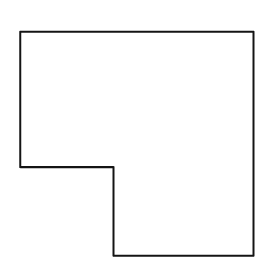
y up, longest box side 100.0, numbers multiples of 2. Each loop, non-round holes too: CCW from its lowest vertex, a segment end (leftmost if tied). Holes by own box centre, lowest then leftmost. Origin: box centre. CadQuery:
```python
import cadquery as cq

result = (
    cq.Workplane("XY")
    .moveTo(-10.0, -48.0)
    .lineTo(50.0, -48.0)
    .lineTo(50.0, 48.0)
    .lineTo(-50.0, 48.0)
    .lineTo(-50.0, -10.0)
    .lineTo(-10.0, -10.0)
    .close()
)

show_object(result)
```